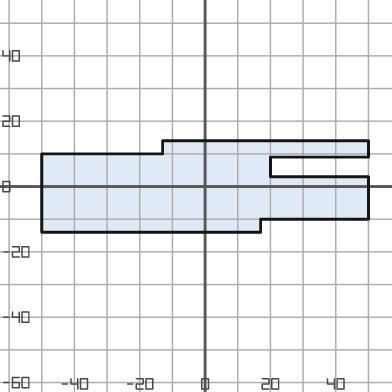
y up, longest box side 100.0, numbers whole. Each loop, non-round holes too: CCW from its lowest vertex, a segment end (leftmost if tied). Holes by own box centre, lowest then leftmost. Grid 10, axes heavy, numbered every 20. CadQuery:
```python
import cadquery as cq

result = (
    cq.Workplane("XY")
    .moveTo(-50.0, -14.0)
    .lineTo(17.0, -14.0)
    .lineTo(17.0, -10.0)
    .lineTo(50.0, -10.0)
    .lineTo(50.0, 3.0)
    .lineTo(20.0, 3.0)
    .lineTo(20.0, 9.0)
    .lineTo(50.0, 9.0)
    .lineTo(50.0, 14.0)
    .lineTo(-13.0, 14.0)
    .lineTo(-13.0, 10.0)
    .lineTo(-50.0, 10.0)
    .close()
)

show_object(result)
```